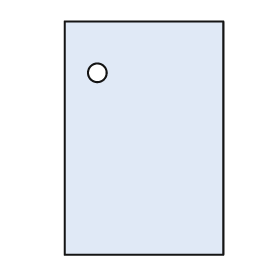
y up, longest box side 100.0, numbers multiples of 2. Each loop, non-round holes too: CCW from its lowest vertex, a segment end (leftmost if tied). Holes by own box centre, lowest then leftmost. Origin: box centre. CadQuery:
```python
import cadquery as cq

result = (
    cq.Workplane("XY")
    .moveTo(-34.0, -50.0)
    .lineTo(34.0, -50.0)
    .lineTo(34.0, 50.0)
    .lineTo(-34.0, 50.0)
    .close()
    .moveTo(-20.0, 28.0)
    .circle(4.0)
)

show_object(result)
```